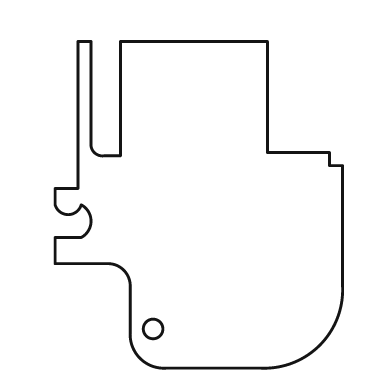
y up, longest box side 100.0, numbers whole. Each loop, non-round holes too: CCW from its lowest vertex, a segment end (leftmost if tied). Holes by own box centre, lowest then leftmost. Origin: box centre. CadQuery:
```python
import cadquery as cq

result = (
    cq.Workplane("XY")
    .moveTo(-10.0, -50.0)
    .lineTo(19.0, -50.0)
    .threePointArc((37.0, -43.0), (44.0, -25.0))
    .lineTo(44.0, 12.0)
    .lineTo(40.0, 12.0)
    .lineTo(40.0, 16.0)
    .lineTo(21.0, 16.0)
    .lineTo(21.0, 50.0)
    .lineTo(-24.0, 50.0)
    .lineTo(-24.0, 15.0)
    .lineTo(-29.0, 15.0)
    .threePointArc((-32.0, 16.0), (-33.0, 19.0))
    .lineTo(-33.0, 50.0)
    .lineTo(-37.0, 50.0)
    .lineTo(-37.0, 5.0)
    .lineTo(-44.0, 5.0)
    .lineTo(-44.0, 0.0)
    .threePointArc((-40.0, -3.0), (-36.0, 0.0))
    .threePointArc((-33.0, -5.0), (-36.0, -10.0))
    .lineTo(-44.0, -10.0)
    .lineTo(-44.0, -18.0)
    .lineTo(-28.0, -18.0)
    .threePointArc((-23.0, -20.0), (-21.0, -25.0))
    .lineTo(-21.0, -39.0)
    .threePointArc((-18.0, -47.0), (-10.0, -50.0))
    .close()
    .moveTo(-14.0, -38.0)
    .circle(3.0)
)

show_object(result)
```